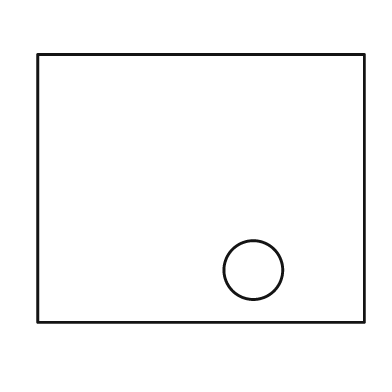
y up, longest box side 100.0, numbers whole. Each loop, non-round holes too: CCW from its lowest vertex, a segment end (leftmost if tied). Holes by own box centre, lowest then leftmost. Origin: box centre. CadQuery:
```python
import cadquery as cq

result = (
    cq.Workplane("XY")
    .moveTo(-50.0, -41.0)
    .lineTo(50.0, -41.0)
    .lineTo(50.0, 41.0)
    .lineTo(-50.0, 41.0)
    .close()
    .moveTo(16.0, -25.0)
    .circle(9.0)
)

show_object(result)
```